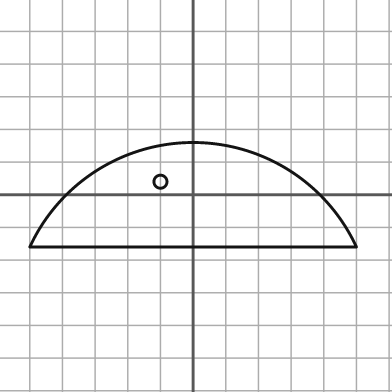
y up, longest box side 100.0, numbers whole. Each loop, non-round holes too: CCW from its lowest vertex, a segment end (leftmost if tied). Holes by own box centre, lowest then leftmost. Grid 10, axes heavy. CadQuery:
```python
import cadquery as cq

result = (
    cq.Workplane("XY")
    .moveTo(-50.0, -16.0)
    .lineTo(50.0, -16.0)
    .threePointArc((0.0, 16.0), (-50.0, -16.0))
    .close()
    .moveTo(-10.0, 4.0)
    .circle(2.0)
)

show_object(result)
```